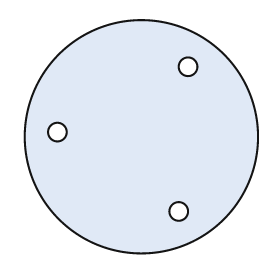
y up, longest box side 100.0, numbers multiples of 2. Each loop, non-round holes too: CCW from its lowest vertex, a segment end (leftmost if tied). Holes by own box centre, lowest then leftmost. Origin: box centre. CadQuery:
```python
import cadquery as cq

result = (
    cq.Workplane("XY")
    .moveTo(0.0, 0.0)
    .circle(50.0)
    .moveTo(16.0, -32.0)
    .circle(4.0)
    .moveTo(-36.0, 2.0)
    .circle(4.0)
    .moveTo(20.0, 30.0)
    .circle(4.0)
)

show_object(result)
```